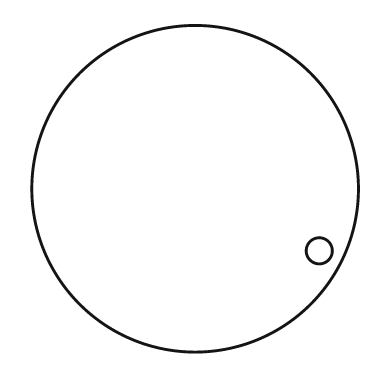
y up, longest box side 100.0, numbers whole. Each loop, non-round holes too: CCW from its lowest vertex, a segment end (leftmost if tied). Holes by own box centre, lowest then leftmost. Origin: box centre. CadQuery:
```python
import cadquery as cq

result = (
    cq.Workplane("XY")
    .moveTo(0.0, 0.0)
    .circle(50.0)
    .moveTo(38.0, -19.0)
    .circle(4.0)
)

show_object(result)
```